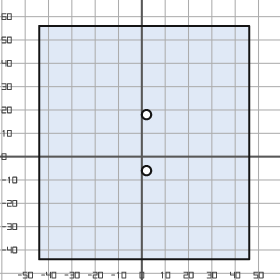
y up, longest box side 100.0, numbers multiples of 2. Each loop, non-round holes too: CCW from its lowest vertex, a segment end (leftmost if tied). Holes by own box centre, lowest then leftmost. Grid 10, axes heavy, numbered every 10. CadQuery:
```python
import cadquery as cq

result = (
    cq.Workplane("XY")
    .moveTo(-44.0, -44.0)
    .lineTo(46.0, -44.0)
    .lineTo(46.0, 56.0)
    .lineTo(-44.0, 56.0)
    .close()
    .moveTo(2.0, -6.0)
    .circle(2.0)
    .moveTo(2.0, 18.0)
    .circle(2.0)
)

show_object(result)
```